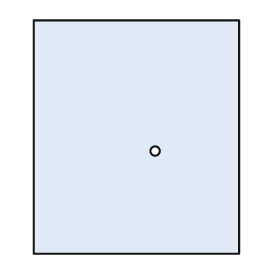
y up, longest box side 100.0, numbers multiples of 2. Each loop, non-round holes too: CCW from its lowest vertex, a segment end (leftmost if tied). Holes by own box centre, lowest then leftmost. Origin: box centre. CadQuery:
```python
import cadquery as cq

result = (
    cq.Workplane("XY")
    .moveTo(-44.0, -50.0)
    .lineTo(44.0, -50.0)
    .lineTo(44.0, 50.0)
    .lineTo(-44.0, 50.0)
    .close()
    .moveTo(8.0, -6.0)
    .circle(2.0)
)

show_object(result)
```